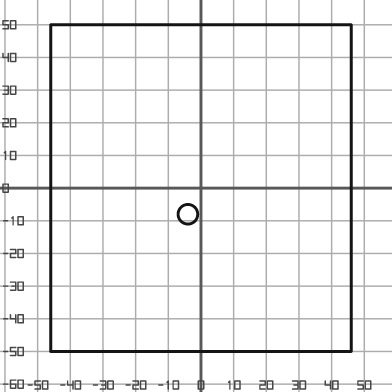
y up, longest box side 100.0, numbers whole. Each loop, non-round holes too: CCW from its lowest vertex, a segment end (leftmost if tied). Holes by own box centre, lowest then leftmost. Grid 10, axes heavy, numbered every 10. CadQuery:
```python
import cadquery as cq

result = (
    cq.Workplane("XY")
    .moveTo(-46.0, -50.0)
    .lineTo(46.0, -50.0)
    .lineTo(46.0, 50.0)
    .lineTo(-46.0, 50.0)
    .close()
    .moveTo(-4.0, -8.0)
    .circle(3.0)
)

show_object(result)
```